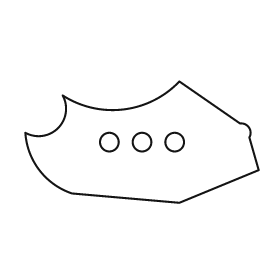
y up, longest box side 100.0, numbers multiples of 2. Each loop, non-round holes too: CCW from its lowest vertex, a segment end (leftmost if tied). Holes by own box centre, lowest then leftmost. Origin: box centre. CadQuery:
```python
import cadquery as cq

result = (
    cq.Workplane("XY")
    .moveTo(16.0, -26.0)
    .lineTo(50.0, -12.0)
    .lineTo(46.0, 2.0)
    .threePointArc((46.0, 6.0), (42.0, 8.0))
    .lineTo(16.0, 26.0)
    .threePointArc((-8.0, 14.0), (-34.0, 20.0))
    .threePointArc((-36.0, 6.0), (-50.0, 4.0))
    .threePointArc((-44.0, -12.0), (-30.0, -22.0))
    .close()
    .moveTo(-14.0, 0.0)
    .circle(4.0)
    .moveTo(0.0, 0.0)
    .circle(4.0)
    .moveTo(14.0, 0.0)
    .circle(4.0)
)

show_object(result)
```